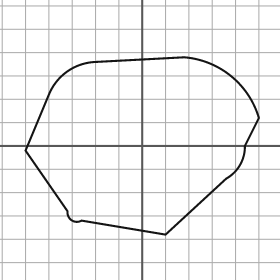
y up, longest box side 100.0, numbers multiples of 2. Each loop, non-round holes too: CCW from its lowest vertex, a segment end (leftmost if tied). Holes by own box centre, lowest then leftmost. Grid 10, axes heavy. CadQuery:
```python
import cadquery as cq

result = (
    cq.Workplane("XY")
    .moveTo(10.0, -38.0)
    .lineTo(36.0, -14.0)
    .threePointArc((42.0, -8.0), (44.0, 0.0))
    .lineTo(50.0, 12.0)
    .threePointArc((38.0, 30.0), (18.0, 38.0))
    .lineTo(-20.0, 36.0)
    .threePointArc((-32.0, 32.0), (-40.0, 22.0))
    .lineTo(-50.0, -2.0)
    .lineTo(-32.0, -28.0)
    .threePointArc((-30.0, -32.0), (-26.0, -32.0))
    .close()
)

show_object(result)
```